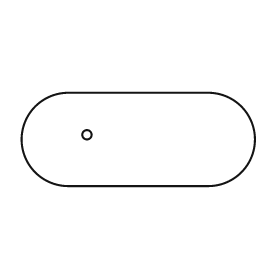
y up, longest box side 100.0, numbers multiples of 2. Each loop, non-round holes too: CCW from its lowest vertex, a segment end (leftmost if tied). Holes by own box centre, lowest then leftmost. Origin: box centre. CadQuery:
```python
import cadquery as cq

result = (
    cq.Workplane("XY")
    .moveTo(-30.0, -20.0)
    .lineTo(30.0, -20.0)
    .threePointArc((50.0, 0.0), (30.0, 20.0))
    .lineTo(-30.0, 20.0)
    .threePointArc((-50.0, 0.0), (-30.0, -20.0))
    .close()
    .moveTo(-22.0, 2.0)
    .circle(2.0)
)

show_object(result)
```